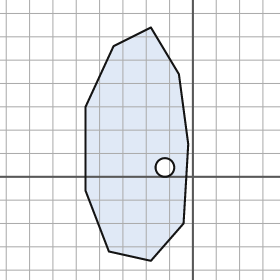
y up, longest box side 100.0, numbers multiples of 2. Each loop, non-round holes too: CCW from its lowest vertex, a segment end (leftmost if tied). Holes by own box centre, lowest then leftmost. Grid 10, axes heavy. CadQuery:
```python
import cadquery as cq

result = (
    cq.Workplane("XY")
    .moveTo(-18.0, -36.0)
    .lineTo(-4.0, -20.0)
    .lineTo(-2.0, 14.0)
    .lineTo(-6.0, 44.0)
    .lineTo(-18.0, 64.0)
    .lineTo(-34.0, 56.0)
    .lineTo(-46.0, 30.0)
    .lineTo(-46.0, -6.0)
    .lineTo(-36.0, -32.0)
    .close()
    .moveTo(-12.0, 4.0)
    .circle(4.0)
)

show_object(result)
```